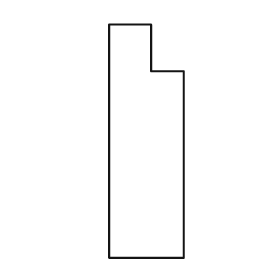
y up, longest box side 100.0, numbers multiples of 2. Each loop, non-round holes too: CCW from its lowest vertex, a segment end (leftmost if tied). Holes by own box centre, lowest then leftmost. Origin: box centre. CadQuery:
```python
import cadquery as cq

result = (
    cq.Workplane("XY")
    .moveTo(-16.0, -50.0)
    .lineTo(16.0, -50.0)
    .lineTo(16.0, 30.0)
    .lineTo(2.0, 30.0)
    .lineTo(2.0, 50.0)
    .lineTo(-16.0, 50.0)
    .close()
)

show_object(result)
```